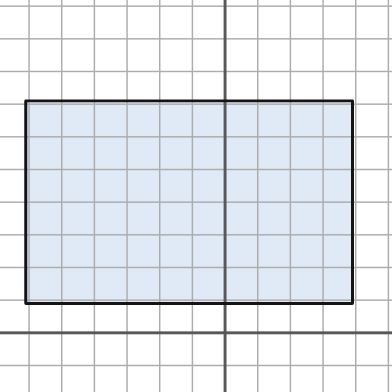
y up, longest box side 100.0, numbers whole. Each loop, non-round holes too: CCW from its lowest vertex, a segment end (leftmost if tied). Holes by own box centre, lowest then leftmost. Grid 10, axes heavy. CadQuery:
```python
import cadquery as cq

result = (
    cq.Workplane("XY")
    .moveTo(-61.0, 9.0)
    .lineTo(39.0, 9.0)
    .lineTo(39.0, 71.0)
    .lineTo(-61.0, 71.0)
    .close()
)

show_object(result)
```